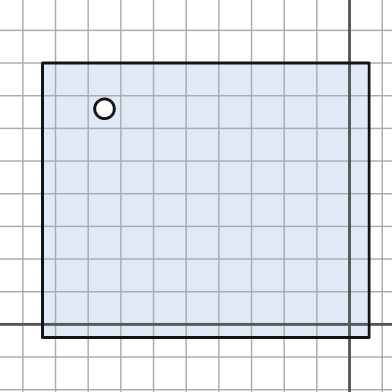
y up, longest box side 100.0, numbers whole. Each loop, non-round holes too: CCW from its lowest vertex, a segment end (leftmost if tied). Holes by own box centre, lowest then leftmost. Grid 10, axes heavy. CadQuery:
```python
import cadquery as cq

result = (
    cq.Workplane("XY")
    .moveTo(-94.0, -4.0)
    .lineTo(6.0, -4.0)
    .lineTo(6.0, 80.0)
    .lineTo(-94.0, 80.0)
    .close()
    .moveTo(-75.0, 66.0)
    .circle(3.0)
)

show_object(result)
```